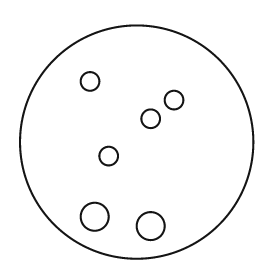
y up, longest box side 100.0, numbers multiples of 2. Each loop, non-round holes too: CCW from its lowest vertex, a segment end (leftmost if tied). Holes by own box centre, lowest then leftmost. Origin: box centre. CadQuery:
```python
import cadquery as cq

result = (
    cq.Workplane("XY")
    .moveTo(0.0, 0.0)
    .circle(50.0)
    .moveTo(6.0, -36.0)
    .circle(6.0)
    .moveTo(-18.0, -32.0)
    .circle(6.0)
    .moveTo(-12.0, -6.0)
    .circle(4.0)
    .moveTo(6.0, 10.0)
    .circle(4.0)
    .moveTo(16.0, 18.0)
    .circle(4.0)
    .moveTo(-20.0, 26.0)
    .circle(4.0)
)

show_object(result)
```